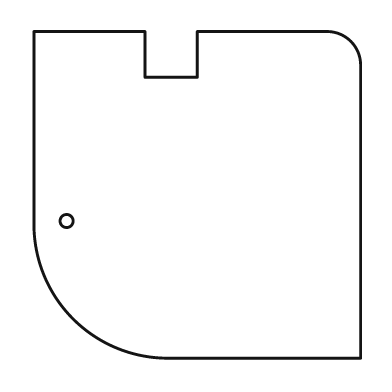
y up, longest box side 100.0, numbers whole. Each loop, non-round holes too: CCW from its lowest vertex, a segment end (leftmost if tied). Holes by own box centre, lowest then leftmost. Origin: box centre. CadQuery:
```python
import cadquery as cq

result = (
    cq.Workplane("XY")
    .moveTo(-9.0, -50.0)
    .lineTo(50.0, -50.0)
    .lineTo(50.0, 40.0)
    .threePointArc((47.0, 47.0), (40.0, 50.0))
    .lineTo(0.0, 50.0)
    .lineTo(0.0, 36.0)
    .lineTo(-16.0, 36.0)
    .lineTo(-16.0, 50.0)
    .lineTo(-50.0, 50.0)
    .lineTo(-50.0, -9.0)
    .threePointArc((-38.0, -38.0), (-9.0, -50.0))
    .close()
    .moveTo(-40.0, -8.0)
    .circle(2.0)
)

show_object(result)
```